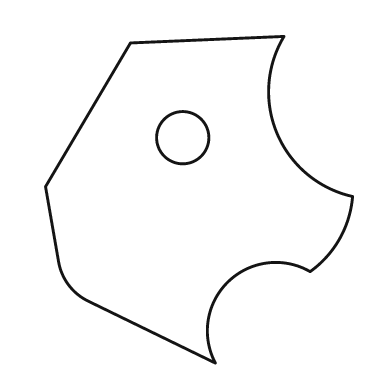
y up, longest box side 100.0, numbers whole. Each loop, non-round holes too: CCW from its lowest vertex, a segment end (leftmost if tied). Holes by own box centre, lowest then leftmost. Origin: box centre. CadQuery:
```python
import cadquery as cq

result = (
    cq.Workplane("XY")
    .moveTo(5.0, -50.0)
    .threePointArc((9.0, -25.0), (34.0, -22.0))
    .threePointArc((43.0, -12.0), (47.0, 1.0))
    .threePointArc((24.0, 20.0), (26.0, 50.0))
    .lineTo(-21.0, 48.0)
    .lineTo(-47.0, 4.0)
    .lineTo(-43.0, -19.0)
    .threePointArc((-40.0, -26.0), (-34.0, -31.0))
    .close()
    .moveTo(-5.0, 19.0)
    .circle(8.0)
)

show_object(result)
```